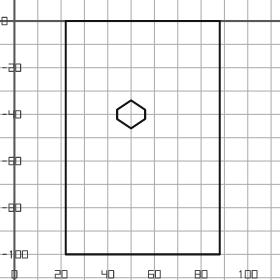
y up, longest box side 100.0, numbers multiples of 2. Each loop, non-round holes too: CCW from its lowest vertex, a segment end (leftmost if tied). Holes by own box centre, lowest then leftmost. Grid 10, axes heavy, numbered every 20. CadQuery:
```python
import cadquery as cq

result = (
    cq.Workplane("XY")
    .moveTo(22.0, -100.0)
    .lineTo(88.0, -100.0)
    .lineTo(88.0, 0.0)
    .lineTo(22.0, 0.0)
    .close()
    .moveTo(50.0, -46.0)
    .lineTo(56.0, -42.0)
    .lineTo(56.0, -38.0)
    .lineTo(50.0, -34.0)
    .lineTo(44.0, -38.0)
    .lineTo(44.0, -42.0)
    .close()
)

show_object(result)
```